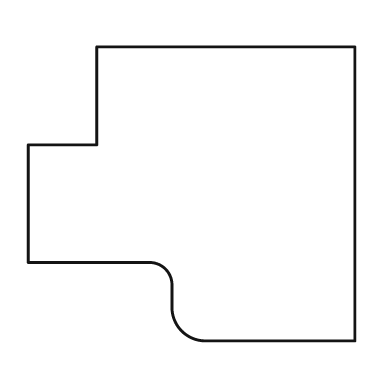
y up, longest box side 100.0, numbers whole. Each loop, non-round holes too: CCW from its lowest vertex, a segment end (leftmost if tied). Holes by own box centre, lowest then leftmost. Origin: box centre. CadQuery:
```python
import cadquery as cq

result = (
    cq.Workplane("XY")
    .moveTo(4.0, -45.0)
    .lineTo(50.0, -45.0)
    .lineTo(50.0, 45.0)
    .lineTo(-29.0, 45.0)
    .lineTo(-29.0, 15.0)
    .lineTo(-50.0, 15.0)
    .lineTo(-50.0, -21.0)
    .lineTo(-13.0, -21.0)
    .threePointArc((-8.0, -23.0), (-6.0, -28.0))
    .lineTo(-6.0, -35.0)
    .threePointArc((-3.0, -42.0), (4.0, -45.0))
    .close()
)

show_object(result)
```